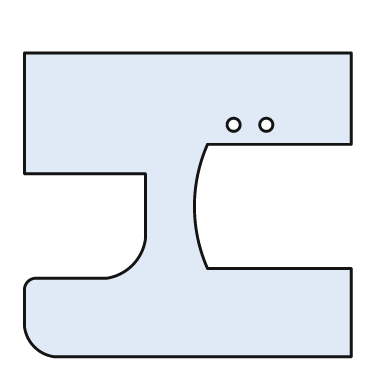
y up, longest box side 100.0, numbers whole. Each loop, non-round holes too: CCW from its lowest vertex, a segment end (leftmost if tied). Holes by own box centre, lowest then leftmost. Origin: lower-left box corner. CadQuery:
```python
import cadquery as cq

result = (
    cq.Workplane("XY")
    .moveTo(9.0, 0.0)
    .lineTo(100.0, 0.0)
    .lineTo(100.0, 27.0)
    .lineTo(56.0, 27.0)
    .threePointArc((52.0, 46.0), (56.0, 65.0))
    .lineTo(100.0, 65.0)
    .lineTo(100.0, 93.0)
    .lineTo(0.0, 93.0)
    .lineTo(0.0, 56.0)
    .lineTo(37.0, 56.0)
    .lineTo(37.0, 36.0)
    .threePointArc((33.0, 28.0), (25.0, 24.0))
    .lineTo(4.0, 24.0)
    .threePointArc((1.0, 23.0), (0.0, 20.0))
    .lineTo(0.0, 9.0)
    .threePointArc((3.0, 3.0), (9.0, 0.0))
    .close()
    .moveTo(64.0, 71.0)
    .circle(2.0)
    .moveTo(74.0, 71.0)
    .circle(2.0)
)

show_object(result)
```